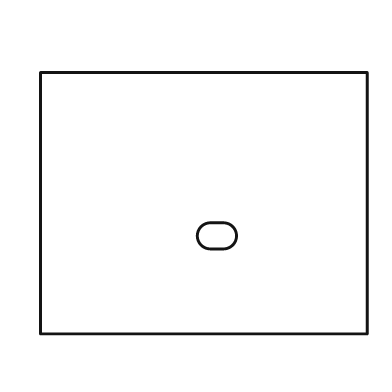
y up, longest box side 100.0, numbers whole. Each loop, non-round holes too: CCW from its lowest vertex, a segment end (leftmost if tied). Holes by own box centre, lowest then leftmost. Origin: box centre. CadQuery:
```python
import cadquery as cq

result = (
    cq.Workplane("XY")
    .moveTo(-50.0, -40.0)
    .lineTo(50.0, -40.0)
    .lineTo(50.0, 40.0)
    .lineTo(-50.0, 40.0)
    .close()
    .moveTo(2.0, -14.0)
    .lineTo(6.0, -14.0)
    .threePointArc((10.0, -10.0), (6.0, -6.0))
    .lineTo(2.0, -6.0)
    .threePointArc((-2.0, -10.0), (2.0, -14.0))
    .close()
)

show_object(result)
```